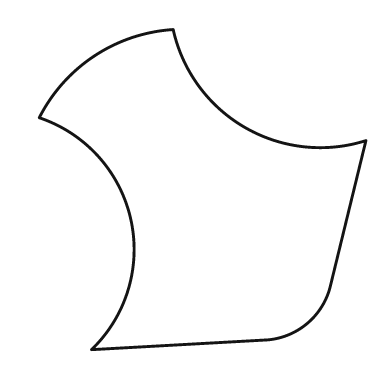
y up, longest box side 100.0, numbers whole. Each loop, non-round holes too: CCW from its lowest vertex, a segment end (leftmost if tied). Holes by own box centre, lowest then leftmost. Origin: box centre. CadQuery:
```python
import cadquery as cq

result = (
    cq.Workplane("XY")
    .moveTo(-34.0, -49.0)
    .lineTo(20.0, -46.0)
    .threePointArc((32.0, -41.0), (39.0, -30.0))
    .lineTo(50.0, 15.0)
    .threePointArc((13.0, 19.0), (-9.0, 49.0))
    .threePointArc((-33.0, 41.0), (-50.0, 22.0))
    .threePointArc((-22.0, -9.0), (-34.0, -49.0))
    .close()
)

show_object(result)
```